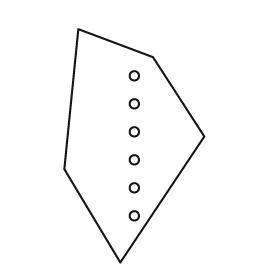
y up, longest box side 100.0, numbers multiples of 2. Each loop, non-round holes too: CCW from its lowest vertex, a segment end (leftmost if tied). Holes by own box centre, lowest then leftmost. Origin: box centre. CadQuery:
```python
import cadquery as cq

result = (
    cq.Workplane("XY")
    .moveTo(-6.0, -50.0)
    .lineTo(30.0, 4.0)
    .lineTo(8.0, 38.0)
    .lineTo(-24.0, 50.0)
    .lineTo(-30.0, -10.0)
    .close()
    .moveTo(0.0, -30.0)
    .circle(2.0)
    .moveTo(0.0, -18.0)
    .circle(2.0)
    .moveTo(0.0, -6.0)
    .circle(2.0)
    .moveTo(0.0, 6.0)
    .circle(2.0)
    .moveTo(0.0, 18.0)
    .circle(2.0)
    .moveTo(0.0, 30.0)
    .circle(2.0)
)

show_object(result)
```